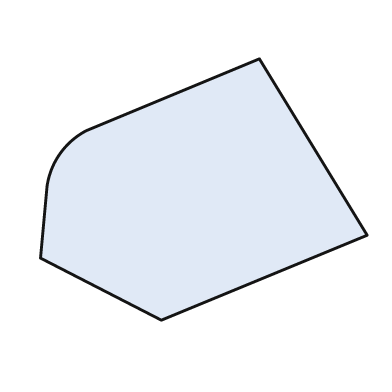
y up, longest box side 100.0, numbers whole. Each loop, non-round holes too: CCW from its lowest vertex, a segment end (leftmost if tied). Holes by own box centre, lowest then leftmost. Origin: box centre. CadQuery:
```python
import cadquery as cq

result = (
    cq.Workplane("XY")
    .moveTo(-13.0, -40.0)
    .lineTo(50.0, -14.0)
    .lineTo(17.0, 40.0)
    .lineTo(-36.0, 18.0)
    .threePointArc((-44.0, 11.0), (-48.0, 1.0))
    .lineTo(-50.0, -21.0)
    .close()
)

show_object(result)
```